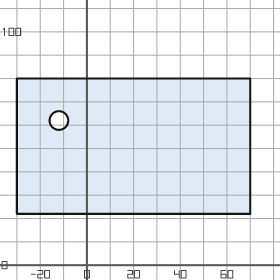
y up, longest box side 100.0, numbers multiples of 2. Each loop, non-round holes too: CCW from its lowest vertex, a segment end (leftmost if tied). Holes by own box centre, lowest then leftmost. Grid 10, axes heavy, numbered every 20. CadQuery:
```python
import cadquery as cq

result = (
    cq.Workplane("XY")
    .moveTo(-30.0, 22.0)
    .lineTo(70.0, 22.0)
    .lineTo(70.0, 80.0)
    .lineTo(-30.0, 80.0)
    .close()
    .moveTo(-12.0, 62.0)
    .circle(4.0)
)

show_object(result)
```